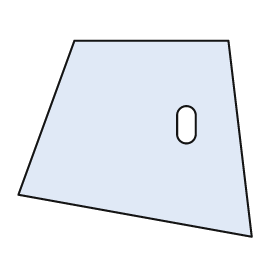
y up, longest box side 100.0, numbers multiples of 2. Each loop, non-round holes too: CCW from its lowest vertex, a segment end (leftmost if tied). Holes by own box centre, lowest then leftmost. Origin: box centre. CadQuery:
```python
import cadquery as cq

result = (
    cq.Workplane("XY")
    .moveTo(50.0, -42.0)
    .lineTo(40.0, 42.0)
    .lineTo(-26.0, 42.0)
    .lineTo(-50.0, -24.0)
    .close()
    .moveTo(18.0, 2.0)
    .threePointArc((22.0, -2.0), (26.0, 2.0))
    .lineTo(26.0, 10.0)
    .threePointArc((22.0, 14.0), (18.0, 10.0))
    .close()
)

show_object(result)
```